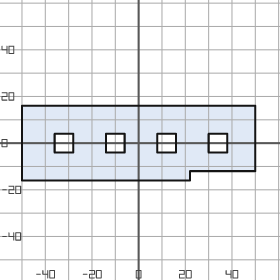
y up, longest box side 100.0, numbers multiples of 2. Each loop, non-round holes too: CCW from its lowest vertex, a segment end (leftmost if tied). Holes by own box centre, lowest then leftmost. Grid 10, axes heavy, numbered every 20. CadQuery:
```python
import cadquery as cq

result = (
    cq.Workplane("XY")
    .moveTo(-50.0, -16.0)
    .lineTo(22.0, -16.0)
    .lineTo(22.0, -12.0)
    .lineTo(50.0, -12.0)
    .lineTo(50.0, 16.0)
    .lineTo(-50.0, 16.0)
    .close()
    .moveTo(-36.0, -4.0)
    .lineTo(-28.0, -4.0)
    .lineTo(-28.0, 4.0)
    .lineTo(-36.0, 4.0)
    .close()
    .moveTo(-14.0, -4.0)
    .lineTo(-6.0, -4.0)
    .lineTo(-6.0, 4.0)
    .lineTo(-14.0, 4.0)
    .close()
    .moveTo(8.0, -4.0)
    .lineTo(16.0, -4.0)
    .lineTo(16.0, 4.0)
    .lineTo(8.0, 4.0)
    .close()
    .moveTo(30.0, -4.0)
    .lineTo(38.0, -4.0)
    .lineTo(38.0, 4.0)
    .lineTo(30.0, 4.0)
    .close()
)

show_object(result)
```